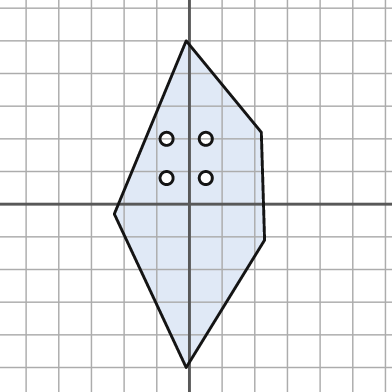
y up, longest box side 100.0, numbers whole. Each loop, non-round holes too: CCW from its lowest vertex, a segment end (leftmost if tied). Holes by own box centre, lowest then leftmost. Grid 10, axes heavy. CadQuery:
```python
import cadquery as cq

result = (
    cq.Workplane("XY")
    .moveTo(-1.0, -50.0)
    .lineTo(23.0, -11.0)
    .lineTo(22.0, 22.0)
    .lineTo(-1.0, 50.0)
    .lineTo(-23.0, -3.0)
    .close()
    .moveTo(-7.0, 8.0)
    .circle(2.0)
    .moveTo(5.0, 8.0)
    .circle(2.0)
    .moveTo(-7.0, 20.0)
    .circle(2.0)
    .moveTo(5.0, 20.0)
    .circle(2.0)
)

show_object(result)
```